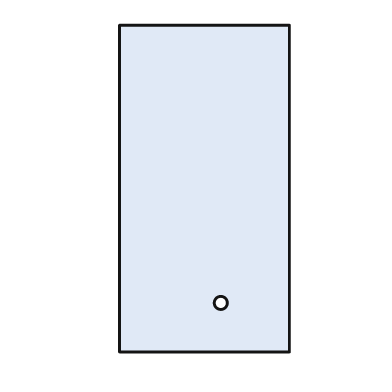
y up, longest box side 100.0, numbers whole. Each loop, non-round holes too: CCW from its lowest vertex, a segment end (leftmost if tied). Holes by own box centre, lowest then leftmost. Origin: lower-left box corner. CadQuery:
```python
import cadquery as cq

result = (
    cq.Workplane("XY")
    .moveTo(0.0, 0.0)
    .lineTo(52.0, 0.0)
    .lineTo(52.0, 100.0)
    .lineTo(0.0, 100.0)
    .close()
    .moveTo(31.0, 15.0)
    .circle(2.0)
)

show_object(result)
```